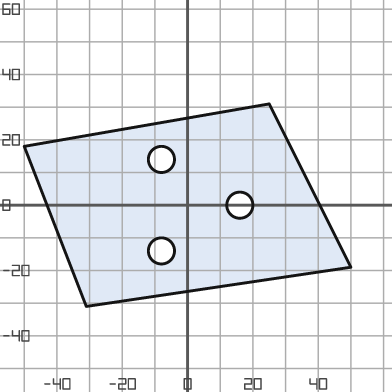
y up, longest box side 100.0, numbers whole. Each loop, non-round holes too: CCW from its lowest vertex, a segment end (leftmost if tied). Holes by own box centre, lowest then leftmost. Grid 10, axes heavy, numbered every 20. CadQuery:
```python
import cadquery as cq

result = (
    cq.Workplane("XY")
    .moveTo(-31.0, -31.0)
    .lineTo(50.0, -19.0)
    .lineTo(25.0, 31.0)
    .lineTo(-50.0, 18.0)
    .close()
    .moveTo(-8.0, -14.0)
    .circle(4.0)
    .moveTo(16.0, 0.0)
    .circle(4.0)
    .moveTo(-8.0, 14.0)
    .circle(4.0)
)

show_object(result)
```